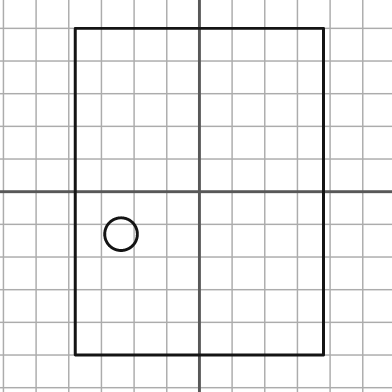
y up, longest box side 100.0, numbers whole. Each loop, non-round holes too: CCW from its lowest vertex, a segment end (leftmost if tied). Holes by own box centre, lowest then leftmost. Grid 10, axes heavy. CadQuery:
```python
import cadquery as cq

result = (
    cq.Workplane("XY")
    .moveTo(-38.0, -50.0)
    .lineTo(38.0, -50.0)
    .lineTo(38.0, 50.0)
    .lineTo(-38.0, 50.0)
    .close()
    .moveTo(-24.0, -13.0)
    .circle(5.0)
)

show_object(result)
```